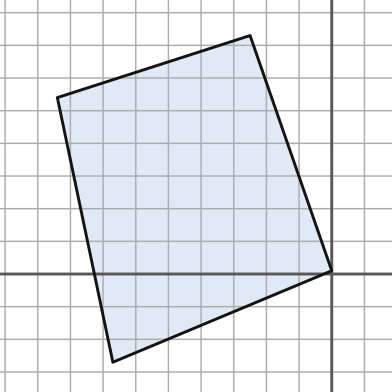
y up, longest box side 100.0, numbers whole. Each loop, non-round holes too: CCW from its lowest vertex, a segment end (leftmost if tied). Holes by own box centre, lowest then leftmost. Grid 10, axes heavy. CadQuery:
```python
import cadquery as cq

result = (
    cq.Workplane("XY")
    .moveTo(-67.0, -27.0)
    .lineTo(0.0, 1.0)
    .lineTo(-25.0, 73.0)
    .lineTo(-84.0, 54.0)
    .close()
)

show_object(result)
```